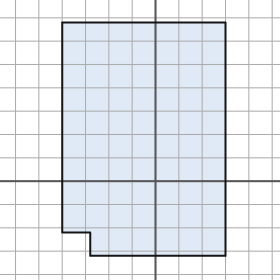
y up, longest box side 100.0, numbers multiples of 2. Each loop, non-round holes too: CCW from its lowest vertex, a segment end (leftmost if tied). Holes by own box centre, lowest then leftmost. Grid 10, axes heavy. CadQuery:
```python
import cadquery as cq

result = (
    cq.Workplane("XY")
    .moveTo(-28.0, -32.0)
    .lineTo(30.0, -32.0)
    .lineTo(30.0, 68.0)
    .lineTo(-40.0, 68.0)
    .lineTo(-40.0, -22.0)
    .lineTo(-28.0, -22.0)
    .close()
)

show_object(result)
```